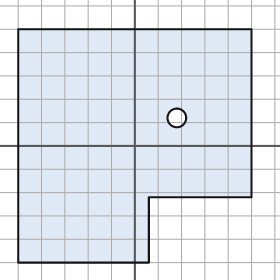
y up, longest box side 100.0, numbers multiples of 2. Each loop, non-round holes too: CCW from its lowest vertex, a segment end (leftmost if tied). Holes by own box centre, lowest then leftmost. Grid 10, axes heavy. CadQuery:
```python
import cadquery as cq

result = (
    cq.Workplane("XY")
    .moveTo(-50.0, -50.0)
    .lineTo(6.0, -50.0)
    .lineTo(6.0, -22.0)
    .lineTo(50.0, -22.0)
    .lineTo(50.0, 50.0)
    .lineTo(-50.0, 50.0)
    .close()
    .moveTo(18.0, 12.0)
    .circle(4.0)
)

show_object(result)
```